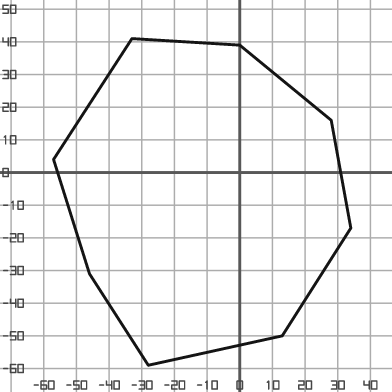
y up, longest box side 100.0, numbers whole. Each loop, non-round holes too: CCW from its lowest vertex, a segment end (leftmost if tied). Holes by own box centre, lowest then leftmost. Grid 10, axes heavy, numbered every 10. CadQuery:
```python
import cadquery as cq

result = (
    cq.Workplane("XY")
    .moveTo(-28.0, -59.0)
    .lineTo(13.0, -50.0)
    .lineTo(34.0, -17.0)
    .lineTo(28.0, 16.0)
    .lineTo(0.0, 39.0)
    .lineTo(-33.0, 41.0)
    .lineTo(-57.0, 4.0)
    .lineTo(-46.0, -31.0)
    .close()
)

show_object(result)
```